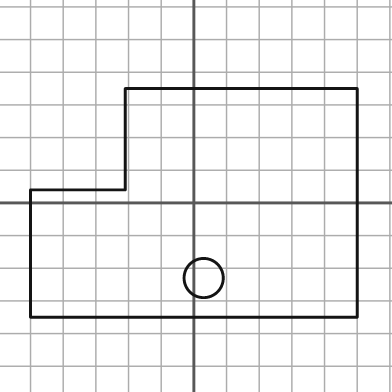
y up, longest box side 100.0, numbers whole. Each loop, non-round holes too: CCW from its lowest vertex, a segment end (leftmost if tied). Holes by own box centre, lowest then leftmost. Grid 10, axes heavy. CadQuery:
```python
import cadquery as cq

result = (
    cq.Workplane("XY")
    .moveTo(-50.0, -35.0)
    .lineTo(50.0, -35.0)
    .lineTo(50.0, 35.0)
    .lineTo(-21.0, 35.0)
    .lineTo(-21.0, 4.0)
    .lineTo(-50.0, 4.0)
    .close()
    .moveTo(3.0, -23.0)
    .circle(6.0)
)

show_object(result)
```